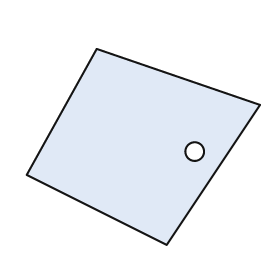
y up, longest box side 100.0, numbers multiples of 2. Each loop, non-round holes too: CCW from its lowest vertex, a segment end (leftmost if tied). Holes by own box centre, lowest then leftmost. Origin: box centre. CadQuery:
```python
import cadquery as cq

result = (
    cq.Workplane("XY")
    .moveTo(10.0, -42.0)
    .lineTo(50.0, 18.0)
    .lineTo(-20.0, 42.0)
    .lineTo(-50.0, -12.0)
    .close()
    .moveTo(22.0, -2.0)
    .circle(4.0)
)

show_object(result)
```